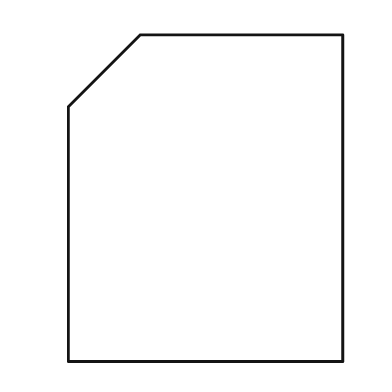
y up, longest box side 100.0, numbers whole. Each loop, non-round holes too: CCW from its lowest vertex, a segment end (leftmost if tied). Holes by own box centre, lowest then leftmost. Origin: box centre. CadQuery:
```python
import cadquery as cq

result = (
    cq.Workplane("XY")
    .moveTo(-42.0, -50.0)
    .lineTo(42.0, -50.0)
    .lineTo(42.0, 50.0)
    .lineTo(-20.0, 50.0)
    .lineTo(-42.0, 28.0)
    .close()
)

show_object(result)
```